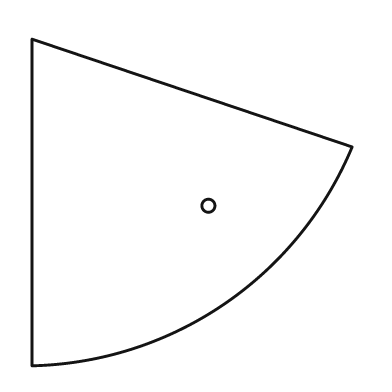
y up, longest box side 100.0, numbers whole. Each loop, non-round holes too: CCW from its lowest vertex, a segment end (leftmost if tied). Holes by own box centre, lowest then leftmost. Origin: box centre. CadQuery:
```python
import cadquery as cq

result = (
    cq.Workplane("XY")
    .moveTo(-49.0, -50.0)
    .threePointArc((10.0, -31.0), (49.0, 17.0))
    .lineTo(-49.0, 50.0)
    .close()
    .moveTo(5.0, -1.0)
    .circle(2.0)
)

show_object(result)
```